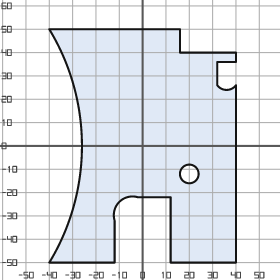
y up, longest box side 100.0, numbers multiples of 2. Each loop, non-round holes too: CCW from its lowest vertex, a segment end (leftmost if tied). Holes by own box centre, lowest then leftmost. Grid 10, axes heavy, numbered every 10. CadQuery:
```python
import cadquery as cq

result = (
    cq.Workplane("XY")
    .moveTo(-40.0, -50.0)
    .lineTo(-12.0, -50.0)
    .lineTo(-12.0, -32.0)
    .threePointArc((-10.0, -24.0), (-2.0, -22.0))
    .lineTo(12.0, -22.0)
    .lineTo(12.0, -50.0)
    .lineTo(40.0, -50.0)
    .lineTo(40.0, 26.0)
    .threePointArc((36.0, 24.0), (32.0, 26.0))
    .lineTo(32.0, 36.0)
    .lineTo(40.0, 36.0)
    .lineTo(40.0, 40.0)
    .lineTo(16.0, 40.0)
    .lineTo(16.0, 50.0)
    .lineTo(-40.0, 50.0)
    .threePointArc((-26.0, 0.0), (-40.0, -50.0))
    .close()
    .moveTo(20.0, -12.0)
    .circle(4.0)
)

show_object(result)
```